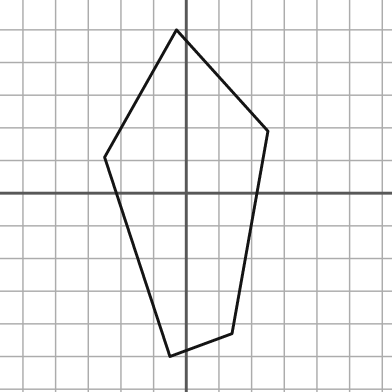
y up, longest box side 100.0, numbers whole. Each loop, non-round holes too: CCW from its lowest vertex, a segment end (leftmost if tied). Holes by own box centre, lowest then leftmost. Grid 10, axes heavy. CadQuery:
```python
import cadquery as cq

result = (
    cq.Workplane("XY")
    .moveTo(-5.0, -50.0)
    .lineTo(14.0, -43.0)
    .lineTo(25.0, 19.0)
    .lineTo(-3.0, 50.0)
    .lineTo(-25.0, 11.0)
    .close()
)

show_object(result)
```